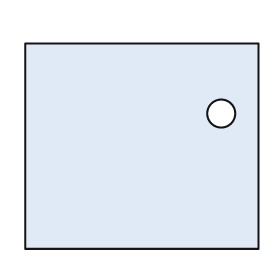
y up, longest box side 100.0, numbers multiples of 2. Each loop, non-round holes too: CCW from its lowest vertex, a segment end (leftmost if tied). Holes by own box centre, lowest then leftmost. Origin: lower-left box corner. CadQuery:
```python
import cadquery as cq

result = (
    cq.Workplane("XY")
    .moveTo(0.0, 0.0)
    .lineTo(100.0, 0.0)
    .lineTo(100.0, 88.0)
    .lineTo(0.0, 88.0)
    .close()
    .moveTo(84.0, 58.0)
    .circle(6.0)
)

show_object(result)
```